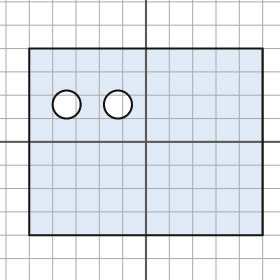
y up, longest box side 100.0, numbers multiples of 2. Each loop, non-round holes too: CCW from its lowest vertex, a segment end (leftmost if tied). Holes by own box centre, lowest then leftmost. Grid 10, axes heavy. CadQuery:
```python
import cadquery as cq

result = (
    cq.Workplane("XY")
    .moveTo(-50.0, -40.0)
    .lineTo(50.0, -40.0)
    .lineTo(50.0, 40.0)
    .lineTo(-50.0, 40.0)
    .close()
    .moveTo(-34.0, 16.0)
    .circle(6.0)
    .moveTo(-12.0, 16.0)
    .circle(6.0)
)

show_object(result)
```